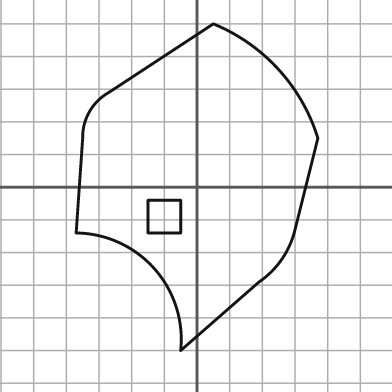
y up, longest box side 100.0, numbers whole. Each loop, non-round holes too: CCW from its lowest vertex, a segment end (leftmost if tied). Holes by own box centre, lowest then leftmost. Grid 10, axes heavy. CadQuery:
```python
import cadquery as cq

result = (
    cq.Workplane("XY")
    .moveTo(-5.0, -50.0)
    .lineTo(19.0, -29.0)
    .threePointArc((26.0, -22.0), (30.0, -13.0))
    .lineTo(37.0, 15.0)
    .threePointArc((25.0, 36.0), (5.0, 50.0))
    .lineTo(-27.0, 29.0)
    .threePointArc((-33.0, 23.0), (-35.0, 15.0))
    .lineTo(-37.0, -14.0)
    .threePointArc((-13.0, -25.0), (-5.0, -50.0))
    .close()
    .moveTo(-15.0, -14.0)
    .lineTo(-5.0, -14.0)
    .lineTo(-5.0, -4.0)
    .lineTo(-15.0, -4.0)
    .close()
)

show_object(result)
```